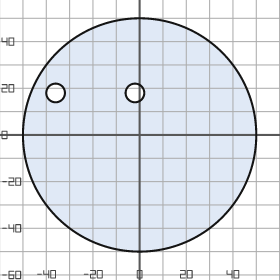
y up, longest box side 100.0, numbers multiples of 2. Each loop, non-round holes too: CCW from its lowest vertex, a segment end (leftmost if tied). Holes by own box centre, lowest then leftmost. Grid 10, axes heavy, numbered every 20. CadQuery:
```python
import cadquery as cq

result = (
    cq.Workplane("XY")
    .moveTo(0.0, 0.0)
    .circle(50.0)
    .moveTo(-36.0, 18.0)
    .circle(4.0)
    .moveTo(-2.0, 18.0)
    .circle(4.0)
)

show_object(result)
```